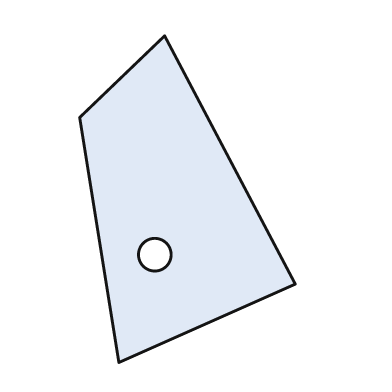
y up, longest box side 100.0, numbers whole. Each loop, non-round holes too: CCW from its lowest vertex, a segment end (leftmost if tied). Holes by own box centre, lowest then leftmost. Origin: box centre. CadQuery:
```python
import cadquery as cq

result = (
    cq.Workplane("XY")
    .moveTo(-21.0, -50.0)
    .lineTo(33.0, -26.0)
    .lineTo(-7.0, 50.0)
    .lineTo(-33.0, 25.0)
    .close()
    .moveTo(-10.0, -17.0)
    .circle(5.0)
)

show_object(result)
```